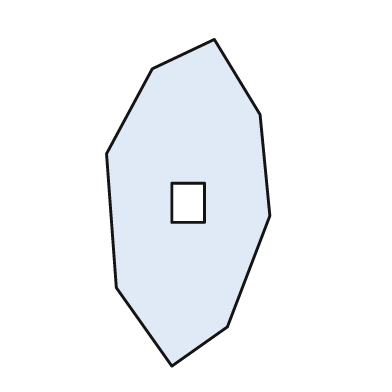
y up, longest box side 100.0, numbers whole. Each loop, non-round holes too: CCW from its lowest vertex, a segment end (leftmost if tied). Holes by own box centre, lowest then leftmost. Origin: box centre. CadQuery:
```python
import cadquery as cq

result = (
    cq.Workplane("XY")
    .moveTo(-5.0, -50.0)
    .lineTo(12.0, -38.0)
    .lineTo(25.0, -4.0)
    .lineTo(22.0, 27.0)
    .lineTo(8.0, 50.0)
    .lineTo(-11.0, 41.0)
    .lineTo(-25.0, 15.0)
    .lineTo(-22.0, -26.0)
    .close()
    .moveTo(-5.0, -6.0)
    .lineTo(5.0, -6.0)
    .lineTo(5.0, 6.0)
    .lineTo(-5.0, 6.0)
    .close()
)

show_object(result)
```